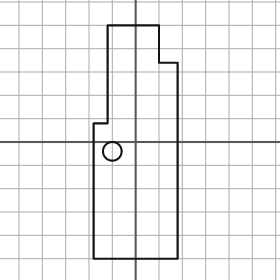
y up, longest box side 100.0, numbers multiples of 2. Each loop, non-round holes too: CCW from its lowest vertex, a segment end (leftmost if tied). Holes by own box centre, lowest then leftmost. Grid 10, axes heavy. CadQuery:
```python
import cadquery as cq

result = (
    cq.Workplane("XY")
    .moveTo(-18.0, -50.0)
    .lineTo(18.0, -50.0)
    .lineTo(18.0, 34.0)
    .lineTo(10.0, 34.0)
    .lineTo(10.0, 50.0)
    .lineTo(-12.0, 50.0)
    .lineTo(-12.0, 8.0)
    .lineTo(-18.0, 8.0)
    .close()
    .moveTo(-10.0, -4.0)
    .circle(4.0)
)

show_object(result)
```